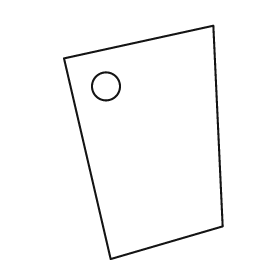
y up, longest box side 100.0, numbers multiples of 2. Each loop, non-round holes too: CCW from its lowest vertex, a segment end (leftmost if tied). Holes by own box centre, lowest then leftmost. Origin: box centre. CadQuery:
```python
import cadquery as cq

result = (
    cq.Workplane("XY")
    .moveTo(-14.0, -50.0)
    .lineTo(34.0, -36.0)
    .lineTo(30.0, 50.0)
    .lineTo(-34.0, 36.0)
    .close()
    .moveTo(-16.0, 24.0)
    .circle(6.0)
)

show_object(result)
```